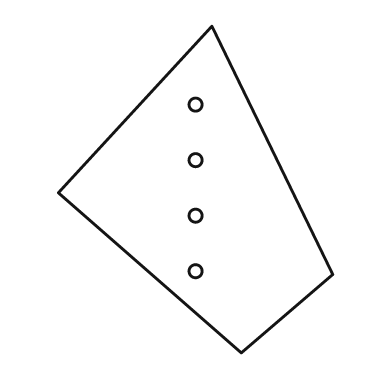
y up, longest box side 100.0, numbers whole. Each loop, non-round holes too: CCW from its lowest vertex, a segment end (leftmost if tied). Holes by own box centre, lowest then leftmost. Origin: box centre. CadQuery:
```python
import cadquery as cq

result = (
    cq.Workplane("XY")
    .moveTo(14.0, -50.0)
    .lineTo(42.0, -26.0)
    .lineTo(5.0, 50.0)
    .lineTo(-42.0, -1.0)
    .close()
    .moveTo(0.0, -25.0)
    .circle(2.0)
    .moveTo(0.0, -8.0)
    .circle(2.0)
    .moveTo(0.0, 9.0)
    .circle(2.0)
    .moveTo(0.0, 26.0)
    .circle(2.0)
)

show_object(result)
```